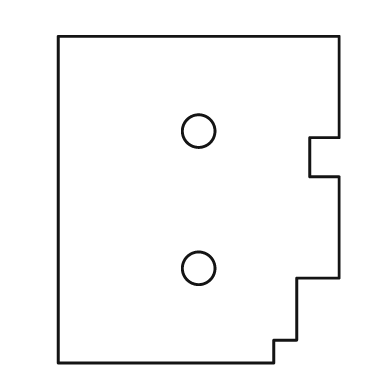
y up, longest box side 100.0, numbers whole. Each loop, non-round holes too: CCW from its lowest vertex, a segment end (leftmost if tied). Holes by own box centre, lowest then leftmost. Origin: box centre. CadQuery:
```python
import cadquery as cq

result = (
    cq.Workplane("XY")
    .moveTo(-43.0, -50.0)
    .lineTo(23.0, -50.0)
    .lineTo(23.0, -43.0)
    .lineTo(30.0, -43.0)
    .lineTo(30.0, -24.0)
    .lineTo(43.0, -24.0)
    .lineTo(43.0, 7.0)
    .lineTo(34.0, 7.0)
    .lineTo(34.0, 19.0)
    .lineTo(43.0, 19.0)
    .lineTo(43.0, 50.0)
    .lineTo(-43.0, 50.0)
    .close()
    .moveTo(0.0, -21.0)
    .circle(5.0)
    .moveTo(0.0, 21.0)
    .circle(5.0)
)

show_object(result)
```